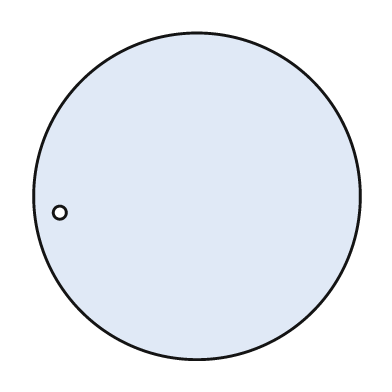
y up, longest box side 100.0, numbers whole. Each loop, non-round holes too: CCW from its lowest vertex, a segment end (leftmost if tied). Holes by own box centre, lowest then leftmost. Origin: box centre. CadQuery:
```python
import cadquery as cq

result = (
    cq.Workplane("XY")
    .moveTo(0.0, 0.0)
    .circle(50.0)
    .moveTo(-42.0, -5.0)
    .circle(2.0)
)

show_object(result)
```